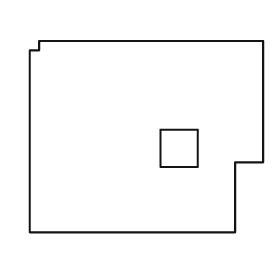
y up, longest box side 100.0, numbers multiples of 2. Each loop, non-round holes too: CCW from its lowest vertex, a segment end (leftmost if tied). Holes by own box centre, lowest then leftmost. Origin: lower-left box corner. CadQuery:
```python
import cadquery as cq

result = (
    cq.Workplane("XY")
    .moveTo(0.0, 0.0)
    .lineTo(88.0, 0.0)
    .lineTo(88.0, 30.0)
    .lineTo(100.0, 30.0)
    .lineTo(100.0, 82.0)
    .lineTo(4.0, 82.0)
    .lineTo(4.0, 78.0)
    .lineTo(0.0, 78.0)
    .close()
    .moveTo(56.0, 28.0)
    .lineTo(72.0, 28.0)
    .lineTo(72.0, 44.0)
    .lineTo(56.0, 44.0)
    .close()
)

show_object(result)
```